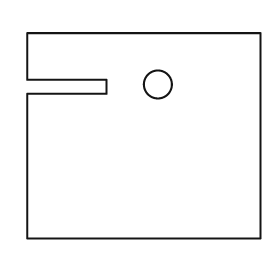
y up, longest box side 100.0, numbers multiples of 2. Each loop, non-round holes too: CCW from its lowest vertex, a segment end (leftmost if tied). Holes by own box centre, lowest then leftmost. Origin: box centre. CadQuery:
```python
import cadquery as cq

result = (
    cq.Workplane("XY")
    .moveTo(-50.0, -44.0)
    .lineTo(50.0, -44.0)
    .lineTo(50.0, 44.0)
    .lineTo(-50.0, 44.0)
    .lineTo(-50.0, 24.0)
    .lineTo(-16.0, 24.0)
    .lineTo(-16.0, 18.0)
    .lineTo(-50.0, 18.0)
    .close()
    .moveTo(6.0, 22.0)
    .circle(6.0)
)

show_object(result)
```